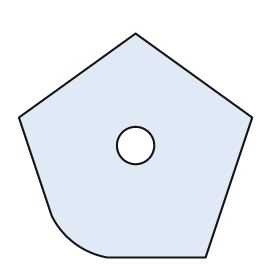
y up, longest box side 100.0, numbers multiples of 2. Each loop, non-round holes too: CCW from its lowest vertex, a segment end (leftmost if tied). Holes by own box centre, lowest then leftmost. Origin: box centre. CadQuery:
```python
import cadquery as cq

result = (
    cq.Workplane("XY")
    .moveTo(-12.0, -48.0)
    .lineTo(30.0, -48.0)
    .lineTo(50.0, 12.0)
    .lineTo(0.0, 48.0)
    .lineTo(-50.0, 12.0)
    .lineTo(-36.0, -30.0)
    .threePointArc((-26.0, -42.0), (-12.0, -48.0))
    .close()
    .moveTo(0.0, 0.0)
    .circle(8.0)
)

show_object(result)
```